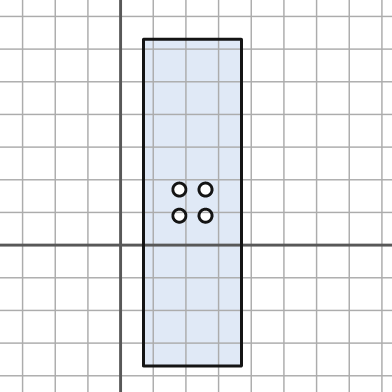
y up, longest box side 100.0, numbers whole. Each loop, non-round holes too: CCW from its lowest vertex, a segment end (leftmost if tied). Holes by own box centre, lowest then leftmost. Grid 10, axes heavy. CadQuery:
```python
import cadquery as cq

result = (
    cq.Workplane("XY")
    .moveTo(7.0, -37.0)
    .lineTo(37.0, -37.0)
    .lineTo(37.0, 63.0)
    .lineTo(7.0, 63.0)
    .close()
    .moveTo(18.0, 9.0)
    .circle(2.0)
    .moveTo(26.0, 9.0)
    .circle(2.0)
    .moveTo(18.0, 17.0)
    .circle(2.0)
    .moveTo(26.0, 17.0)
    .circle(2.0)
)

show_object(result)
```